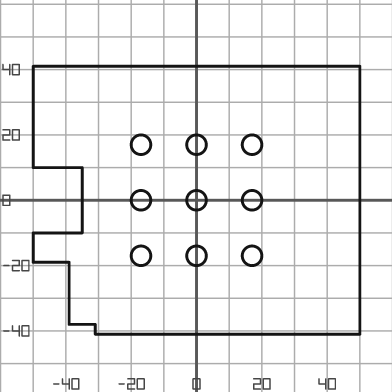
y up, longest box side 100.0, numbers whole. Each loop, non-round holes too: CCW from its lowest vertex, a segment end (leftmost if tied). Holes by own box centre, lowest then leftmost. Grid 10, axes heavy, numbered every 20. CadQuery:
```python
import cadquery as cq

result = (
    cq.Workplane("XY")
    .moveTo(-31.0, -41.0)
    .lineTo(50.0, -41.0)
    .lineTo(50.0, 41.0)
    .lineTo(-50.0, 41.0)
    .lineTo(-50.0, 10.0)
    .lineTo(-35.0, 10.0)
    .lineTo(-35.0, -10.0)
    .lineTo(-50.0, -10.0)
    .lineTo(-50.0, -19.0)
    .lineTo(-39.0, -19.0)
    .lineTo(-39.0, -38.0)
    .lineTo(-31.0, -38.0)
    .close()
    .moveTo(-17.0, -17.0)
    .circle(3.0)
    .moveTo(0.0, -17.0)
    .circle(3.0)
    .moveTo(17.0, -17.0)
    .circle(3.0)
    .moveTo(-17.0, 0.0)
    .circle(3.0)
    .moveTo(0.0, 0.0)
    .circle(3.0)
    .moveTo(17.0, 0.0)
    .circle(3.0)
    .moveTo(-17.0, 17.0)
    .circle(3.0)
    .moveTo(0.0, 17.0)
    .circle(3.0)
    .moveTo(17.0, 17.0)
    .circle(3.0)
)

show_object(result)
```